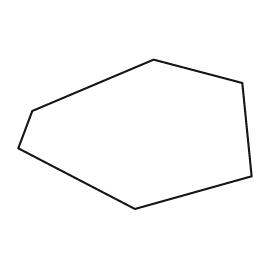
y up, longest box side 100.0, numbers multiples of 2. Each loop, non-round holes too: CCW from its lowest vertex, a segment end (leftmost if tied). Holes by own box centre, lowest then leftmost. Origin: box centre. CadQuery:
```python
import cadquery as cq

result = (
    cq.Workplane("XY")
    .moveTo(0.0, -32.0)
    .lineTo(50.0, -18.0)
    .lineTo(46.0, 22.0)
    .lineTo(8.0, 32.0)
    .lineTo(-44.0, 10.0)
    .lineTo(-50.0, -6.0)
    .close()
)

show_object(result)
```